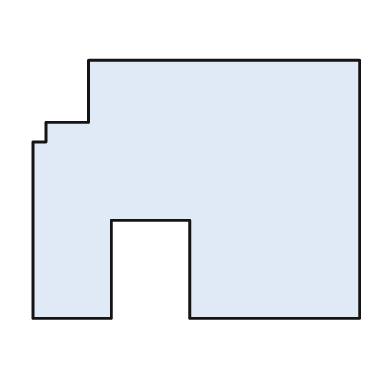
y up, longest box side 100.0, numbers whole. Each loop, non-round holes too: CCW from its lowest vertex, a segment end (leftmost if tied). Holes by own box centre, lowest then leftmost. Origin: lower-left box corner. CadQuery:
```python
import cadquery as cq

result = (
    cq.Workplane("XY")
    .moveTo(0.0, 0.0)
    .lineTo(24.0, 0.0)
    .lineTo(24.0, 30.0)
    .lineTo(48.0, 30.0)
    .lineTo(48.0, 0.0)
    .lineTo(100.0, 0.0)
    .lineTo(100.0, 79.0)
    .lineTo(17.0, 79.0)
    .lineTo(17.0, 60.0)
    .lineTo(4.0, 60.0)
    .lineTo(4.0, 54.0)
    .lineTo(0.0, 54.0)
    .close()
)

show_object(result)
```